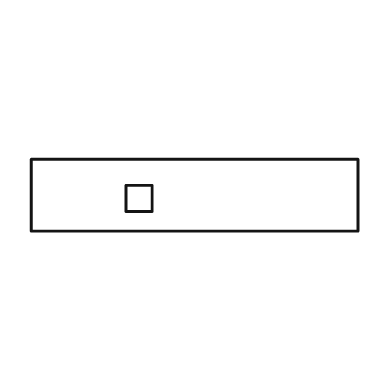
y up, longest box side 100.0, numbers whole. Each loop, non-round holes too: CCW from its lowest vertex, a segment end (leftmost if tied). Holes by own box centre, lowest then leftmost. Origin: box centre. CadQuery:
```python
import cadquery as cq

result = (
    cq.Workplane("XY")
    .moveTo(-50.0, -11.0)
    .lineTo(50.0, -11.0)
    .lineTo(50.0, 11.0)
    .lineTo(-50.0, 11.0)
    .close()
    .moveTo(-21.0, -5.0)
    .lineTo(-13.0, -5.0)
    .lineTo(-13.0, 3.0)
    .lineTo(-21.0, 3.0)
    .close()
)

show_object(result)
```